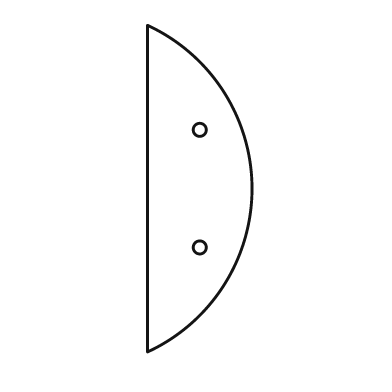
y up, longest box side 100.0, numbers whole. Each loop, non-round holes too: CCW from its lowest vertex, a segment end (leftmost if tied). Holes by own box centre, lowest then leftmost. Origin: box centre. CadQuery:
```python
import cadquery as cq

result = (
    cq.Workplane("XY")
    .moveTo(-16.0, -50.0)
    .threePointArc((16.0, 0.0), (-16.0, 50.0))
    .close()
    .moveTo(0.0, -18.0)
    .circle(2.0)
    .moveTo(0.0, 18.0)
    .circle(2.0)
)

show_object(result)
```